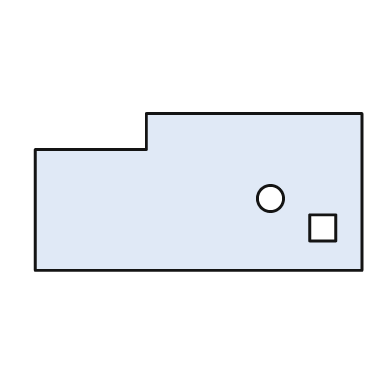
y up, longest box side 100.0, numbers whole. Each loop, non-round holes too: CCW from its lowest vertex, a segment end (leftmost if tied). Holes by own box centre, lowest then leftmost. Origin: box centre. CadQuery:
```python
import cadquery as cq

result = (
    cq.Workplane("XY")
    .moveTo(-50.0, -24.0)
    .lineTo(50.0, -24.0)
    .lineTo(50.0, 24.0)
    .lineTo(-16.0, 24.0)
    .lineTo(-16.0, 13.0)
    .lineTo(-50.0, 13.0)
    .close()
    .moveTo(34.0, -15.0)
    .lineTo(42.0, -15.0)
    .lineTo(42.0, -7.0)
    .lineTo(34.0, -7.0)
    .close()
    .moveTo(22.0, -2.0)
    .circle(4.0)
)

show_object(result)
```